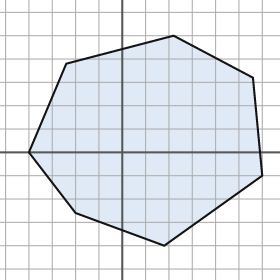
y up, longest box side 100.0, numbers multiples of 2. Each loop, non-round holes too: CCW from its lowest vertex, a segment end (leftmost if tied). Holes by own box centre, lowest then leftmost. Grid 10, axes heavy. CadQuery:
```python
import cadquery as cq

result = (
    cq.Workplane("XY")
    .moveTo(18.0, -40.0)
    .lineTo(60.0, -10.0)
    .lineTo(56.0, 32.0)
    .lineTo(22.0, 50.0)
    .lineTo(-24.0, 38.0)
    .lineTo(-40.0, 0.0)
    .lineTo(-20.0, -26.0)
    .close()
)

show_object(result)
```